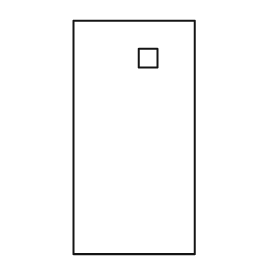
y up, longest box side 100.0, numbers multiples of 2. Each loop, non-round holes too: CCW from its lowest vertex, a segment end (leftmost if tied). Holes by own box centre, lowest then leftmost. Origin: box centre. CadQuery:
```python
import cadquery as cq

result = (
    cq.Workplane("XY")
    .moveTo(-26.0, -50.0)
    .lineTo(26.0, -50.0)
    .lineTo(26.0, 50.0)
    .lineTo(-26.0, 50.0)
    .close()
    .moveTo(2.0, 30.0)
    .lineTo(10.0, 30.0)
    .lineTo(10.0, 38.0)
    .lineTo(2.0, 38.0)
    .close()
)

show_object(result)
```